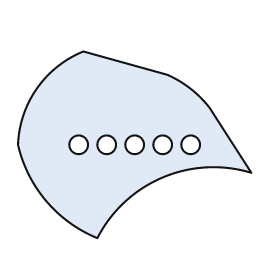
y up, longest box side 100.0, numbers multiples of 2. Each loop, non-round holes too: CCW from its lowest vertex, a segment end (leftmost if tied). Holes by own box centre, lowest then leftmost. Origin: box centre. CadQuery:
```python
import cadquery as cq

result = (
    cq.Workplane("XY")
    .moveTo(-16.0, -40.0)
    .threePointArc((12.0, -14.0), (50.0, -12.0))
    .lineTo(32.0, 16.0)
    .threePointArc((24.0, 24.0), (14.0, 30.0))
    .lineTo(-22.0, 40.0)
    .threePointArc((-42.0, 24.0), (-50.0, 0.0))
    .threePointArc((-38.0, -24.0), (-16.0, -40.0))
    .close()
    .moveTo(-24.0, 0.0)
    .circle(4.0)
    .moveTo(-12.0, 0.0)
    .circle(4.0)
    .moveTo(0.0, 0.0)
    .circle(4.0)
    .moveTo(12.0, 0.0)
    .circle(4.0)
    .moveTo(24.0, 0.0)
    .circle(4.0)
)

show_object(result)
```